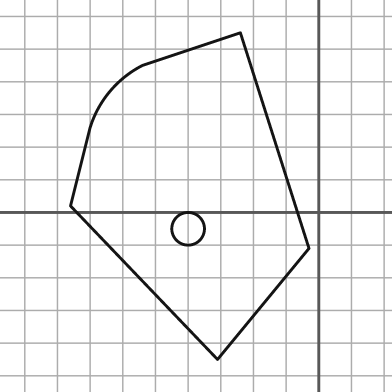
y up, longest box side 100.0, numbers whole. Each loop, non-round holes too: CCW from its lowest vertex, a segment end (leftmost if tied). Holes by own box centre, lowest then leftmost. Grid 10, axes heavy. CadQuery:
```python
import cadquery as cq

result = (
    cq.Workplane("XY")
    .moveTo(-31.0, -45.0)
    .lineTo(-3.0, -11.0)
    .lineTo(-24.0, 55.0)
    .lineTo(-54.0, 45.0)
    .threePointArc((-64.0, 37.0), (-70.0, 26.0))
    .lineTo(-76.0, 2.0)
    .close()
    .moveTo(-40.0, -5.0)
    .circle(5.0)
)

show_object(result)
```